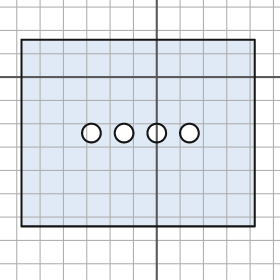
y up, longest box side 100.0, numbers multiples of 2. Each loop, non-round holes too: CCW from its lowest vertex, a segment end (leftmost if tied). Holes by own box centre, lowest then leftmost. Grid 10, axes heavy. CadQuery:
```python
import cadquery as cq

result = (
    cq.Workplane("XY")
    .moveTo(-58.0, -64.0)
    .lineTo(42.0, -64.0)
    .lineTo(42.0, 16.0)
    .lineTo(-58.0, 16.0)
    .close()
    .moveTo(-28.0, -24.0)
    .circle(4.0)
    .moveTo(-14.0, -24.0)
    .circle(4.0)
    .moveTo(0.0, -24.0)
    .circle(4.0)
    .moveTo(14.0, -24.0)
    .circle(4.0)
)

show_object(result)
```